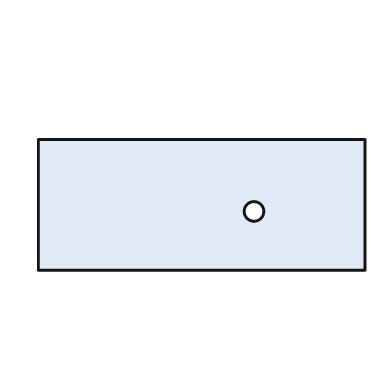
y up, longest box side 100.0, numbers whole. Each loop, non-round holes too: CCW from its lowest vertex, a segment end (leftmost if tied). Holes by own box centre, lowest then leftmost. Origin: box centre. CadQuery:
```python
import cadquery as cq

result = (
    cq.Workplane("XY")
    .moveTo(-50.0, -20.0)
    .lineTo(50.0, -20.0)
    .lineTo(50.0, 20.0)
    .lineTo(-50.0, 20.0)
    .close()
    .moveTo(16.0, -2.0)
    .circle(3.0)
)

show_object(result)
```